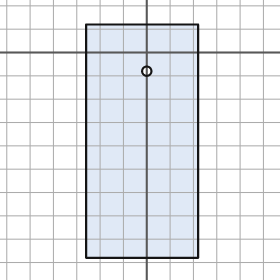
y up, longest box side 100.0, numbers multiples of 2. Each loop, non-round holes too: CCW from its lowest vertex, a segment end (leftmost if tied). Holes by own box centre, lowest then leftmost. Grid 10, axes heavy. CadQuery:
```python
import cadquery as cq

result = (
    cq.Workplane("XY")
    .moveTo(-26.0, -88.0)
    .lineTo(22.0, -88.0)
    .lineTo(22.0, 12.0)
    .lineTo(-26.0, 12.0)
    .close()
    .moveTo(0.0, -8.0)
    .circle(2.0)
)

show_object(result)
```